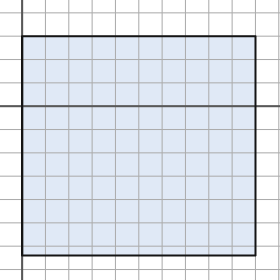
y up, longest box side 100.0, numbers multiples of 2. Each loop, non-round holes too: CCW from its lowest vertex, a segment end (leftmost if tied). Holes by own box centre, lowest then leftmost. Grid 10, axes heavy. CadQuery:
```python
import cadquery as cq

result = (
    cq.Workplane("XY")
    .moveTo(0.0, -64.0)
    .lineTo(100.0, -64.0)
    .lineTo(100.0, 30.0)
    .lineTo(0.0, 30.0)
    .close()
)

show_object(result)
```